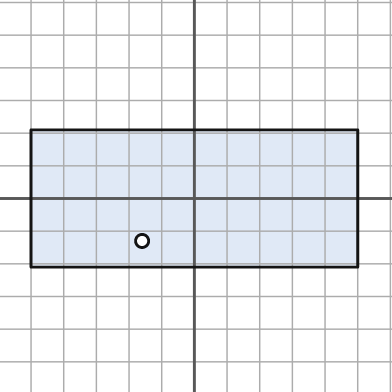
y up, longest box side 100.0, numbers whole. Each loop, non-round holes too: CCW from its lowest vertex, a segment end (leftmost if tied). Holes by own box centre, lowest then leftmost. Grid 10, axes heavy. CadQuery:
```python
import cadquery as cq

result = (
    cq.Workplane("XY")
    .moveTo(-50.0, -21.0)
    .lineTo(50.0, -21.0)
    .lineTo(50.0, 21.0)
    .lineTo(-50.0, 21.0)
    .close()
    .moveTo(-16.0, -13.0)
    .circle(2.0)
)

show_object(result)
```